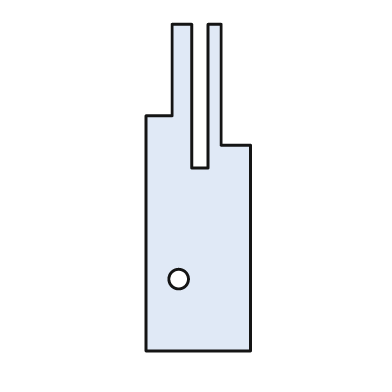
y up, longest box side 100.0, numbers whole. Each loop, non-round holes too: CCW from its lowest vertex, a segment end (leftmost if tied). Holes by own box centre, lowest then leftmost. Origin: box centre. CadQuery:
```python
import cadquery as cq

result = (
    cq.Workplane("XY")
    .moveTo(-16.0, -50.0)
    .lineTo(16.0, -50.0)
    .lineTo(16.0, 13.0)
    .lineTo(7.0, 13.0)
    .lineTo(7.0, 50.0)
    .lineTo(3.0, 50.0)
    .lineTo(3.0, 6.0)
    .lineTo(-2.0, 6.0)
    .lineTo(-2.0, 50.0)
    .lineTo(-8.0, 50.0)
    .lineTo(-8.0, 22.0)
    .lineTo(-16.0, 22.0)
    .close()
    .moveTo(-6.0, -28.0)
    .circle(3.0)
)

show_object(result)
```